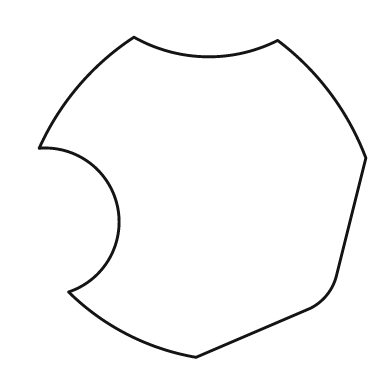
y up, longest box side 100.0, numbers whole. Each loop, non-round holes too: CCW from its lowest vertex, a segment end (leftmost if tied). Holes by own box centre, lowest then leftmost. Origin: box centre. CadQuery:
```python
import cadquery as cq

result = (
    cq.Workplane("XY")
    .moveTo(-2.0, -49.0)
    .lineTo(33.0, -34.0)
    .threePointArc((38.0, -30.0), (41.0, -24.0))
    .lineTo(50.0, 12.0)
    .threePointArc((39.0, 32.0), (23.0, 48.0))
    .threePointArc((1.0, 43.0), (-21.0, 49.0))
    .threePointArc((-38.0, 34.0), (-50.0, 15.0))
    .threePointArc((-26.0, -3.0), (-41.0, -29.0))
    .threePointArc((-23.0, -42.0), (-2.0, -49.0))
    .close()
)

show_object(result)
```